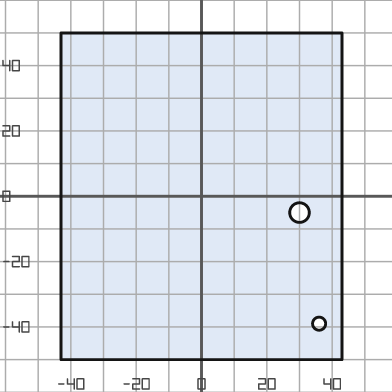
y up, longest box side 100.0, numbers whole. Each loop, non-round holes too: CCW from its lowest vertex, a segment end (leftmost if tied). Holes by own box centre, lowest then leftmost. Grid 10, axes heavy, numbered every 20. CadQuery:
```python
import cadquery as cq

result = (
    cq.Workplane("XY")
    .moveTo(-43.0, -50.0)
    .lineTo(43.0, -50.0)
    .lineTo(43.0, 50.0)
    .lineTo(-43.0, 50.0)
    .close()
    .moveTo(36.0, -39.0)
    .circle(2.0)
    .moveTo(30.0, -5.0)
    .circle(3.0)
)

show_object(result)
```